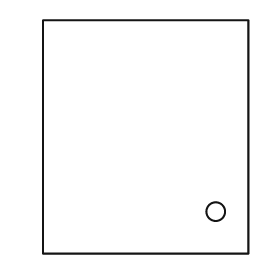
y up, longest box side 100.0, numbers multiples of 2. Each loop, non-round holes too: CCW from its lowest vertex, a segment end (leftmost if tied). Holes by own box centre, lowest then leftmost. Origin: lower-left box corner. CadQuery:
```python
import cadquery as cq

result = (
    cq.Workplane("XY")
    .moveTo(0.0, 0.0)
    .lineTo(88.0, 0.0)
    .lineTo(88.0, 100.0)
    .lineTo(0.0, 100.0)
    .close()
    .moveTo(74.0, 18.0)
    .circle(4.0)
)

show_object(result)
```